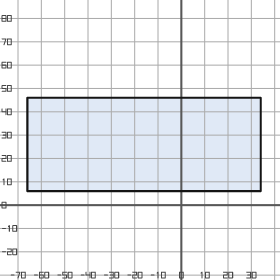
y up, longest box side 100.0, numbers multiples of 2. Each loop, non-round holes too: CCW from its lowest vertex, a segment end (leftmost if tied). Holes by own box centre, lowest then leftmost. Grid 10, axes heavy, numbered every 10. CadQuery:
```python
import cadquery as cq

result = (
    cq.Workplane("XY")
    .moveTo(-66.0, 6.0)
    .lineTo(34.0, 6.0)
    .lineTo(34.0, 46.0)
    .lineTo(-66.0, 46.0)
    .close()
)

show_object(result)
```